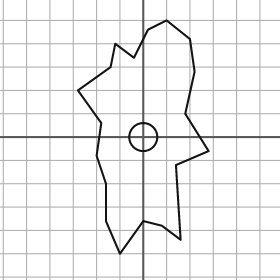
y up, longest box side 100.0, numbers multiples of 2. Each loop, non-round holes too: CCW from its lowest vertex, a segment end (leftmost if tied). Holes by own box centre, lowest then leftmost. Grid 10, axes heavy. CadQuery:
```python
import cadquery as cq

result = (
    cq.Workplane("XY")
    .moveTo(-10.0, -50.0)
    .lineTo(0.0, -36.0)
    .lineTo(8.0, -38.0)
    .lineTo(16.0, -44.0)
    .lineTo(14.0, -12.0)
    .lineTo(28.0, -6.0)
    .lineTo(18.0, 10.0)
    .lineTo(22.0, 28.0)
    .lineTo(20.0, 42.0)
    .lineTo(10.0, 50.0)
    .lineTo(2.0, 46.0)
    .lineTo(-4.0, 34.0)
    .lineTo(-12.0, 40.0)
    .lineTo(-14.0, 30.0)
    .lineTo(-28.0, 20.0)
    .lineTo(-18.0, 6.0)
    .lineTo(-20.0, -8.0)
    .lineTo(-16.0, -20.0)
    .lineTo(-16.0, -36.0)
    .close()
    .moveTo(0.0, 0.0)
    .circle(6.0)
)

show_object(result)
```